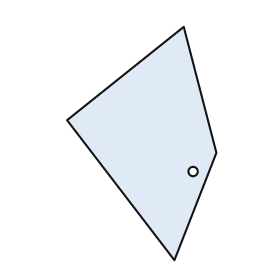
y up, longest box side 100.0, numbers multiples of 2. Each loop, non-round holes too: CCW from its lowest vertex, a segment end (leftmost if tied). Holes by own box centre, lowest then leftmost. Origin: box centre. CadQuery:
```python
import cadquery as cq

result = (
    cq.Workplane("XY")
    .moveTo(14.0, -50.0)
    .lineTo(32.0, -4.0)
    .lineTo(18.0, 50.0)
    .lineTo(-32.0, 10.0)
    .close()
    .moveTo(22.0, -12.0)
    .circle(2.0)
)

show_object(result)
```